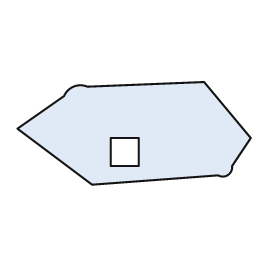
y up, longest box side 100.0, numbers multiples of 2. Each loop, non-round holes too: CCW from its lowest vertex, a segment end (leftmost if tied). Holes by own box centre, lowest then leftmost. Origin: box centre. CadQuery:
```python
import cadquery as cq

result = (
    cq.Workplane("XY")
    .moveTo(-18.0, -22.0)
    .lineTo(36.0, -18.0)
    .threePointArc((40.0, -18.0), (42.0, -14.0))
    .lineTo(50.0, -2.0)
    .lineTo(30.0, 22.0)
    .lineTo(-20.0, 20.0)
    .threePointArc((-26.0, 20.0), (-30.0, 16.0))
    .lineTo(-50.0, 2.0)
    .close()
    .moveTo(-10.0, -14.0)
    .lineTo(2.0, -14.0)
    .lineTo(2.0, -2.0)
    .lineTo(-10.0, -2.0)
    .close()
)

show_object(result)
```